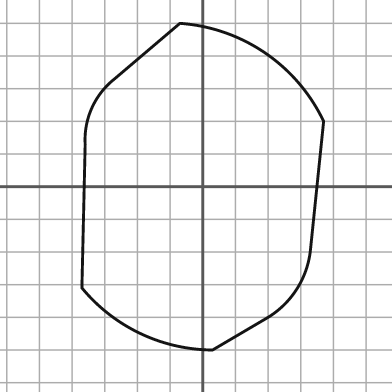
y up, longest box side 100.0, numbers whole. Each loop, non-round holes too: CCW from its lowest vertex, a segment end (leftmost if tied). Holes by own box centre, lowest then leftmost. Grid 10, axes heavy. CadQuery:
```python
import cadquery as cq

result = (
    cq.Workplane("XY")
    .moveTo(3.0, -50.0)
    .lineTo(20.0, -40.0)
    .threePointArc((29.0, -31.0), (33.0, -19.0))
    .lineTo(37.0, 20.0)
    .threePointArc((19.0, 41.0), (-7.0, 50.0))
    .lineTo(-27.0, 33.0)
    .threePointArc((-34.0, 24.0), (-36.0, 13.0))
    .lineTo(-37.0, -31.0)
    .threePointArc((-19.0, -45.0), (3.0, -50.0))
    .close()
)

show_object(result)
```